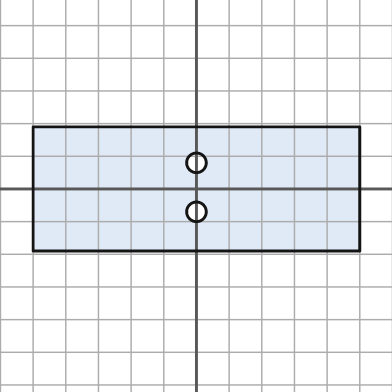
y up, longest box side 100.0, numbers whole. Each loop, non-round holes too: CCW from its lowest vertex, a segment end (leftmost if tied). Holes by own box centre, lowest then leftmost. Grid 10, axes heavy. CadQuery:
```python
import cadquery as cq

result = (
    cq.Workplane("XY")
    .moveTo(-50.0, -19.0)
    .lineTo(50.0, -19.0)
    .lineTo(50.0, 19.0)
    .lineTo(-50.0, 19.0)
    .close()
    .moveTo(0.0, -7.0)
    .circle(3.0)
    .moveTo(0.0, 8.0)
    .circle(3.0)
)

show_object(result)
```